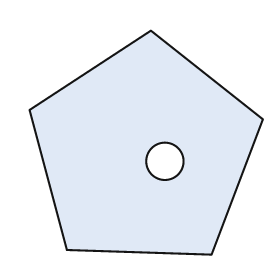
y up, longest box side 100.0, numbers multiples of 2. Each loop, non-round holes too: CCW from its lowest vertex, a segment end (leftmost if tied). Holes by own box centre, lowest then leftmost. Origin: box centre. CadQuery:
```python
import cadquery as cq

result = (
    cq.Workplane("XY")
    .moveTo(28.0, -48.0)
    .lineTo(50.0, 10.0)
    .lineTo(2.0, 48.0)
    .lineTo(-50.0, 14.0)
    .lineTo(-34.0, -46.0)
    .close()
    .moveTo(8.0, -8.0)
    .circle(8.0)
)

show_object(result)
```